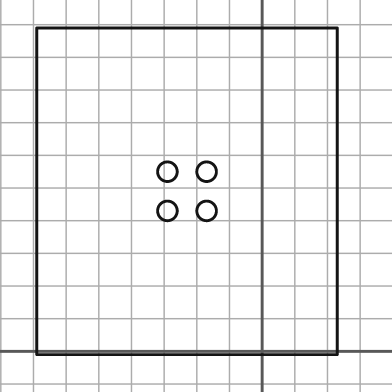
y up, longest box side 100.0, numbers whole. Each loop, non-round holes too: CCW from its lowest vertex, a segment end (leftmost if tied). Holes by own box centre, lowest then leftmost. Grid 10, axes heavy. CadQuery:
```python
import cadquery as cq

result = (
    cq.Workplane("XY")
    .moveTo(-69.0, -1.0)
    .lineTo(23.0, -1.0)
    .lineTo(23.0, 99.0)
    .lineTo(-69.0, 99.0)
    .close()
    .moveTo(-29.0, 43.0)
    .circle(3.0)
    .moveTo(-17.0, 43.0)
    .circle(3.0)
    .moveTo(-29.0, 55.0)
    .circle(3.0)
    .moveTo(-17.0, 55.0)
    .circle(3.0)
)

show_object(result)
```